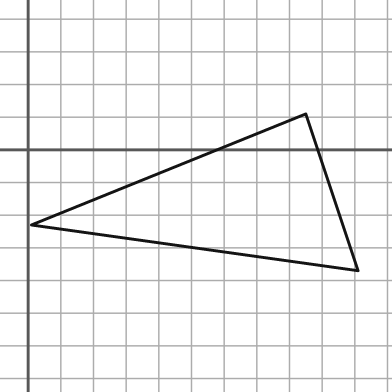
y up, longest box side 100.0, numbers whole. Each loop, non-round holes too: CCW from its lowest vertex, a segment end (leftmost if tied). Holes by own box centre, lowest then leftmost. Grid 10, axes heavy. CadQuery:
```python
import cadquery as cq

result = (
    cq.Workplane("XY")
    .moveTo(101.0, -37.0)
    .lineTo(85.0, 11.0)
    .lineTo(1.0, -23.0)
    .close()
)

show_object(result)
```